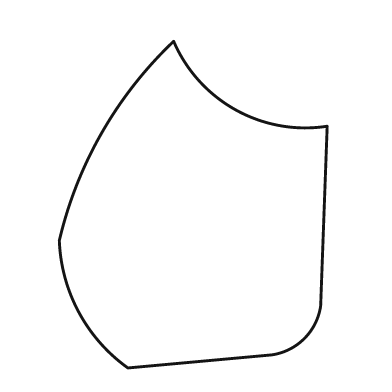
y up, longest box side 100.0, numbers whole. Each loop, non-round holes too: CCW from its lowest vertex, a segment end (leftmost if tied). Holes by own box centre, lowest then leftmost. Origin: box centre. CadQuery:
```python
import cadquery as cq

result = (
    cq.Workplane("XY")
    .moveTo(-20.0, -50.0)
    .lineTo(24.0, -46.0)
    .threePointArc((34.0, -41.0), (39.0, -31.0))
    .lineTo(41.0, 24.0)
    .threePointArc((13.0, 29.0), (-6.0, 50.0))
    .threePointArc((-28.0, 22.0), (-41.0, -11.0))
    .threePointArc((-35.0, -33.0), (-20.0, -50.0))
    .close()
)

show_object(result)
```